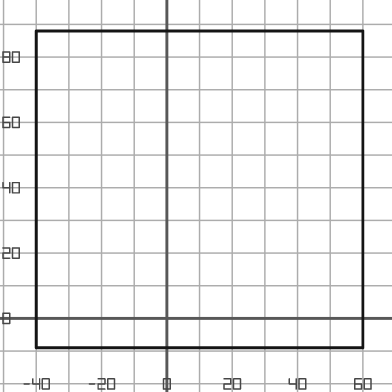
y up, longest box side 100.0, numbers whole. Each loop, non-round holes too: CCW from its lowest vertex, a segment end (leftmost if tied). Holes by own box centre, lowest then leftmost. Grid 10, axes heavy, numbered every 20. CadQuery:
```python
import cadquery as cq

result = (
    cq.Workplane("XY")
    .moveTo(-40.0, -9.0)
    .lineTo(60.0, -9.0)
    .lineTo(60.0, 88.0)
    .lineTo(-40.0, 88.0)
    .close()
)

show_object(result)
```